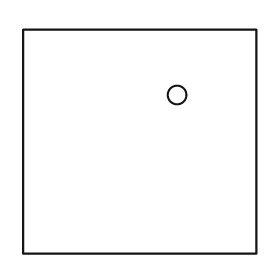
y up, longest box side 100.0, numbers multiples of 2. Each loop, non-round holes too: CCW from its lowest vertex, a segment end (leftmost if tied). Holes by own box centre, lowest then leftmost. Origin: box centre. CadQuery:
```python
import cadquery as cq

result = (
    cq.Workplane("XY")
    .moveTo(-50.0, -48.0)
    .lineTo(50.0, -48.0)
    .lineTo(50.0, 48.0)
    .lineTo(-50.0, 48.0)
    .close()
    .moveTo(16.0, 20.0)
    .circle(4.0)
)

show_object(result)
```